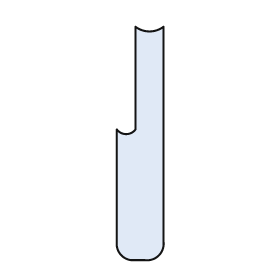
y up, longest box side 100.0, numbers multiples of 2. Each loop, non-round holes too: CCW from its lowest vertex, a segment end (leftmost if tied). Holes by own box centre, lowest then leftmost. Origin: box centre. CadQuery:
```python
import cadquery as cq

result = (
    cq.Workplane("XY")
    .moveTo(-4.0, -50.0)
    .lineTo(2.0, -50.0)
    .threePointArc((8.0, -48.0), (10.0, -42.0))
    .lineTo(10.0, 50.0)
    .threePointArc((4.0, 48.0), (-2.0, 50.0))
    .lineTo(-2.0, 6.0)
    .threePointArc((-6.0, 4.0), (-10.0, 6.0))
    .lineTo(-10.0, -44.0)
    .threePointArc((-8.0, -48.0), (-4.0, -50.0))
    .close()
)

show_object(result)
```